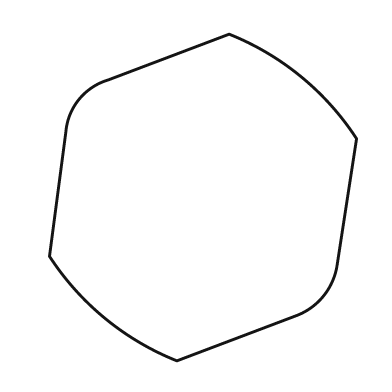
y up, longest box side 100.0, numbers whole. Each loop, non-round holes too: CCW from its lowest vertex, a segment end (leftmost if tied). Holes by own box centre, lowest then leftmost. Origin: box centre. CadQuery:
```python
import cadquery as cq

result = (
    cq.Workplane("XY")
    .moveTo(-8.0, -50.0)
    .lineTo(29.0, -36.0)
    .threePointArc((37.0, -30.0), (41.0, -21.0))
    .lineTo(47.0, 18.0)
    .threePointArc((30.0, 37.0), (8.0, 50.0))
    .lineTo(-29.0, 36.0)
    .threePointArc((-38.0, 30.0), (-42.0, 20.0))
    .lineTo(-47.0, -18.0)
    .threePointArc((-30.0, -37.0), (-8.0, -50.0))
    .close()
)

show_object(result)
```